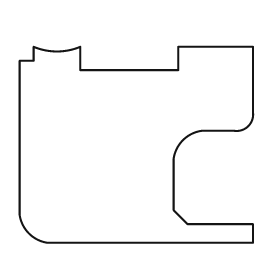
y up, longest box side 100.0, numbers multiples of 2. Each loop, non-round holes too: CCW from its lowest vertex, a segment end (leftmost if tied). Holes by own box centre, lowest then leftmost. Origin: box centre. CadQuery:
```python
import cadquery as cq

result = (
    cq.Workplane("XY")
    .moveTo(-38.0, -42.0)
    .lineTo(50.0, -42.0)
    .lineTo(50.0, -34.0)
    .lineTo(22.0, -34.0)
    .lineTo(16.0, -28.0)
    .lineTo(16.0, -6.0)
    .threePointArc((20.0, 2.0), (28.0, 6.0))
    .lineTo(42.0, 6.0)
    .threePointArc((48.0, 8.0), (50.0, 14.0))
    .lineTo(50.0, 42.0)
    .lineTo(18.0, 42.0)
    .lineTo(18.0, 32.0)
    .lineTo(-24.0, 32.0)
    .lineTo(-24.0, 42.0)
    .threePointArc((-34.0, 40.0), (-44.0, 42.0))
    .lineTo(-44.0, 36.0)
    .lineTo(-50.0, 36.0)
    .lineTo(-50.0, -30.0)
    .threePointArc((-46.0, -38.0), (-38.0, -42.0))
    .close()
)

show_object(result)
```